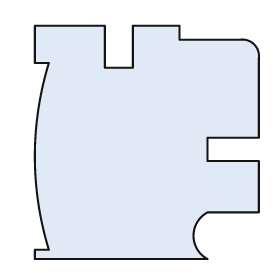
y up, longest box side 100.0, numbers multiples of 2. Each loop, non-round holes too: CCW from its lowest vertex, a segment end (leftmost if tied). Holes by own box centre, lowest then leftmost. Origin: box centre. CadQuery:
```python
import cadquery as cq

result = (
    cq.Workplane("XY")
    .moveTo(-48.0, -50.0)
    .lineTo(26.0, -50.0)
    .threePointArc((20.0, -40.0), (26.0, -30.0))
    .lineTo(48.0, -30.0)
    .lineTo(48.0, -8.0)
    .lineTo(26.0, -8.0)
    .lineTo(26.0, 2.0)
    .lineTo(48.0, 2.0)
    .lineTo(48.0, 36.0)
    .threePointArc((46.0, 42.0), (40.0, 44.0))
    .lineTo(14.0, 44.0)
    .lineTo(14.0, 50.0)
    .lineTo(-6.0, 50.0)
    .lineTo(-6.0, 32.0)
    .lineTo(-18.0, 32.0)
    .lineTo(-18.0, 50.0)
    .lineTo(-48.0, 50.0)
    .lineTo(-48.0, 34.0)
    .lineTo(-42.0, 34.0)
    .threePointArc((-48.0, -6.0), (-42.0, -46.0))
    .lineTo(-48.0, -46.0)
    .close()
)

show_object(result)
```